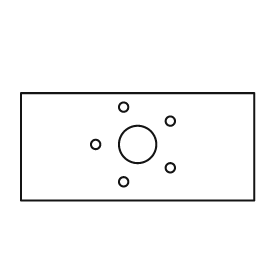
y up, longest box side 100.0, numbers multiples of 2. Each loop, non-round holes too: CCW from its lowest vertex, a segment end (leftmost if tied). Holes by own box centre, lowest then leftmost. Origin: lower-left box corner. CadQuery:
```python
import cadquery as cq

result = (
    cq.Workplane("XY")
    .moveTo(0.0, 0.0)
    .lineTo(100.0, 0.0)
    .lineTo(100.0, 46.0)
    .lineTo(0.0, 46.0)
    .close()
    .moveTo(44.0, 8.0)
    .circle(2.0)
    .moveTo(64.0, 14.0)
    .circle(2.0)
    .moveTo(32.0, 24.0)
    .circle(2.0)
    .moveTo(50.0, 24.0)
    .circle(8.0)
    .moveTo(64.0, 34.0)
    .circle(2.0)
    .moveTo(44.0, 40.0)
    .circle(2.0)
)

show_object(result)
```